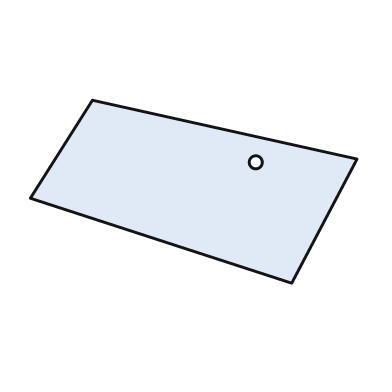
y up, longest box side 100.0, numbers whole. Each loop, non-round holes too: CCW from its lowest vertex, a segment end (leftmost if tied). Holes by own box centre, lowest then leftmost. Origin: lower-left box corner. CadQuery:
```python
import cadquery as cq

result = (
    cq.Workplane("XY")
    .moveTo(80.0, 0.0)
    .lineTo(100.0, 38.0)
    .lineTo(19.0, 56.0)
    .lineTo(0.0, 26.0)
    .close()
    .moveTo(69.0, 37.0)
    .circle(2.0)
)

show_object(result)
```